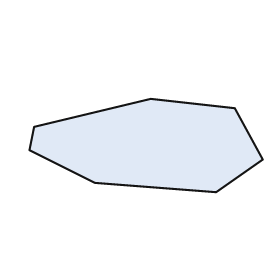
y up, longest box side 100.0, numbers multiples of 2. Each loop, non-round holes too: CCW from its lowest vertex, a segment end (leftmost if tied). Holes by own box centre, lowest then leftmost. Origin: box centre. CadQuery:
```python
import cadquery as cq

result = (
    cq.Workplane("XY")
    .moveTo(30.0, -20.0)
    .lineTo(50.0, -6.0)
    .lineTo(38.0, 16.0)
    .lineTo(2.0, 20.0)
    .lineTo(-48.0, 8.0)
    .lineTo(-50.0, -2.0)
    .lineTo(-22.0, -16.0)
    .close()
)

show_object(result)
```